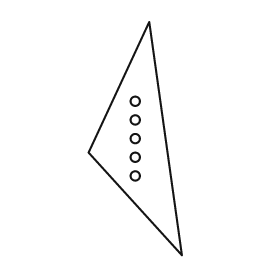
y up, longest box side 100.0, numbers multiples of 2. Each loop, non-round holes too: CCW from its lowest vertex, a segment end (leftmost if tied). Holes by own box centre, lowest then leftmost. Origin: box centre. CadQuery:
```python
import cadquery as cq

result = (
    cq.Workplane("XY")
    .moveTo(20.0, -50.0)
    .lineTo(6.0, 50.0)
    .lineTo(-20.0, -6.0)
    .close()
    .moveTo(0.0, -16.0)
    .circle(2.0)
    .moveTo(0.0, -8.0)
    .circle(2.0)
    .moveTo(0.0, 0.0)
    .circle(2.0)
    .moveTo(0.0, 8.0)
    .circle(2.0)
    .moveTo(0.0, 16.0)
    .circle(2.0)
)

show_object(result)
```